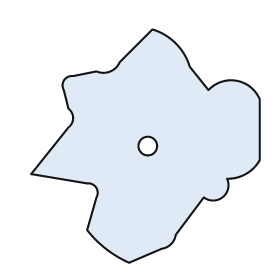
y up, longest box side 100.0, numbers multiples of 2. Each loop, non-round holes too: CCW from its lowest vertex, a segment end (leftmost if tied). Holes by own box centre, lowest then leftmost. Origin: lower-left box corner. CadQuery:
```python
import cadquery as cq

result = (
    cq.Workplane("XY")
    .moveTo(42.0, 0.0)
    .lineTo(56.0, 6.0)
    .threePointArc((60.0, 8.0), (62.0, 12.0))
    .lineTo(74.0, 28.0)
    .threePointArc((82.0, 28.0), (84.0, 36.0))
    .threePointArc((92.0, 38.0), (98.0, 44.0))
    .lineTo(98.0, 70.0)
    .threePointArc((88.0, 78.0), (76.0, 74.0))
    .lineTo(68.0, 84.0)
    .threePointArc((62.0, 94.0), (52.0, 100.0))
    .lineTo(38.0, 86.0)
    .threePointArc((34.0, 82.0), (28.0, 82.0))
    .lineTo(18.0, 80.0)
    .threePointArc((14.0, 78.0), (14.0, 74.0))
    .lineTo(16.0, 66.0)
    .threePointArc((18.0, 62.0), (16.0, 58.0))
    .lineTo(0.0, 38.0)
    .lineTo(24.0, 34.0)
    .threePointArc((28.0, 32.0), (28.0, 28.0))
    .lineTo(24.0, 14.0)
    .threePointArc((32.0, 6.0), (42.0, 0.0))
    .close()
    .moveTo(50.0, 50.0)
    .circle(4.0)
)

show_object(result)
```